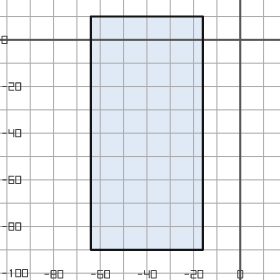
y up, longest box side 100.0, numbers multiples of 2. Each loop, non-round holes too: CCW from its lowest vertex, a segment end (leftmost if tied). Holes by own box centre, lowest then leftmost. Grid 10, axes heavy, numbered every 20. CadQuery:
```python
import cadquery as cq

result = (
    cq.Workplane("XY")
    .moveTo(-64.0, -90.0)
    .lineTo(-16.0, -90.0)
    .lineTo(-16.0, 10.0)
    .lineTo(-64.0, 10.0)
    .close()
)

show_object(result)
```